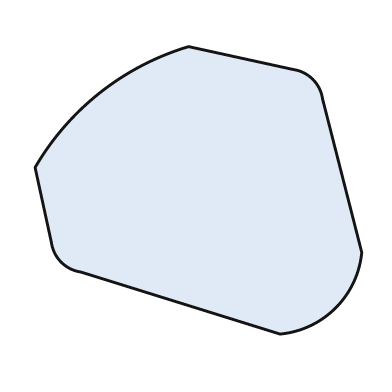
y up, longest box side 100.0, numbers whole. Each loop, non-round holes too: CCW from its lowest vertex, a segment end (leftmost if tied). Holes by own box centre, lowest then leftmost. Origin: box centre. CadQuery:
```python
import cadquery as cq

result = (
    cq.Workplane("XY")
    .moveTo(25.0, -44.0)
    .threePointArc((42.0, -36.0), (50.0, -19.0))
    .lineTo(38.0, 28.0)
    .threePointArc((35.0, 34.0), (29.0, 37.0))
    .lineTo(-3.0, 44.0)
    .threePointArc((-30.0, 30.0), (-50.0, 7.0))
    .lineTo(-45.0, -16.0)
    .threePointArc((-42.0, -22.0), (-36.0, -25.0))
    .close()
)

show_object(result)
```